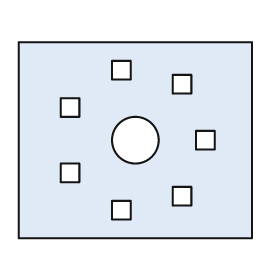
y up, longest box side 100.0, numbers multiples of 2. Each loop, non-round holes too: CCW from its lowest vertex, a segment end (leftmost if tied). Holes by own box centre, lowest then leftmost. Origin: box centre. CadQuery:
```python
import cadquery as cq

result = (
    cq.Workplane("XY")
    .moveTo(-50.0, -42.0)
    .lineTo(50.0, -42.0)
    .lineTo(50.0, 42.0)
    .lineTo(-50.0, 42.0)
    .close()
    .moveTo(-10.0, -34.0)
    .lineTo(-2.0, -34.0)
    .lineTo(-2.0, -26.0)
    .lineTo(-10.0, -26.0)
    .close()
    .moveTo(16.0, -28.0)
    .lineTo(24.0, -28.0)
    .lineTo(24.0, -20.0)
    .lineTo(16.0, -20.0)
    .close()
    .moveTo(-32.0, -18.0)
    .lineTo(-24.0, -18.0)
    .lineTo(-24.0, -10.0)
    .lineTo(-32.0, -10.0)
    .close()
    .moveTo(0.0, 0.0)
    .circle(10.0)
    .moveTo(26.0, -4.0)
    .lineTo(34.0, -4.0)
    .lineTo(34.0, 4.0)
    .lineTo(26.0, 4.0)
    .close()
    .moveTo(-32.0, 10.0)
    .lineTo(-24.0, 10.0)
    .lineTo(-24.0, 18.0)
    .lineTo(-32.0, 18.0)
    .close()
    .moveTo(16.0, 20.0)
    .lineTo(24.0, 20.0)
    .lineTo(24.0, 28.0)
    .lineTo(16.0, 28.0)
    .close()
    .moveTo(-10.0, 26.0)
    .lineTo(-2.0, 26.0)
    .lineTo(-2.0, 34.0)
    .lineTo(-10.0, 34.0)
    .close()
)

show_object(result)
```